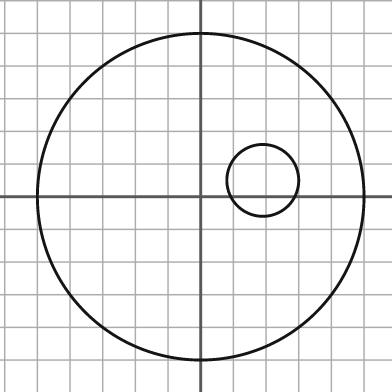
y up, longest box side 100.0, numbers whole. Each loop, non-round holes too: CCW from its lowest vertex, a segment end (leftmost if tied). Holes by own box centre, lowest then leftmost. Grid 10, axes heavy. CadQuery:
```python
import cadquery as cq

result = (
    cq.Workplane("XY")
    .moveTo(0.0, 0.0)
    .circle(50.0)
    .moveTo(19.0, 5.0)
    .circle(11.0)
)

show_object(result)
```